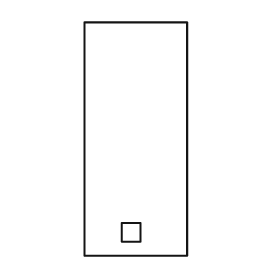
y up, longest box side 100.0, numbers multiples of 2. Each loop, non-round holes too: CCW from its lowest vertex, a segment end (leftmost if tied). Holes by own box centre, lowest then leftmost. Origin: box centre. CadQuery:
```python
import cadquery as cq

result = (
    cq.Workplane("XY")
    .moveTo(-22.0, -50.0)
    .lineTo(22.0, -50.0)
    .lineTo(22.0, 50.0)
    .lineTo(-22.0, 50.0)
    .close()
    .moveTo(-6.0, -44.0)
    .lineTo(2.0, -44.0)
    .lineTo(2.0, -36.0)
    .lineTo(-6.0, -36.0)
    .close()
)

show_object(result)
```